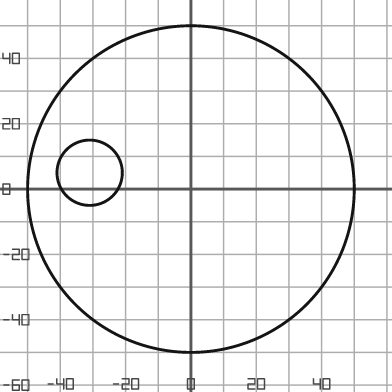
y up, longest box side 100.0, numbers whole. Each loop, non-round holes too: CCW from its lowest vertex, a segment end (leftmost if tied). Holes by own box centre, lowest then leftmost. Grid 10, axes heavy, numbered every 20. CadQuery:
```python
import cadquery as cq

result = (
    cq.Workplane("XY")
    .moveTo(0.0, 0.0)
    .circle(50.0)
    .moveTo(-31.0, 5.0)
    .circle(10.0)
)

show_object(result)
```